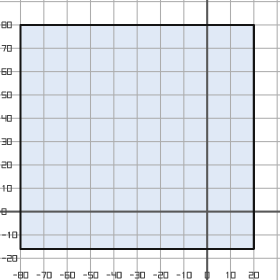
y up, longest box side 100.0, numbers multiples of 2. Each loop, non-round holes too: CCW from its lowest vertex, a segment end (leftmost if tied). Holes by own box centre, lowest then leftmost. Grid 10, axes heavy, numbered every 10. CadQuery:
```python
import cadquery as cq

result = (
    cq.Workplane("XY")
    .moveTo(-80.0, -16.0)
    .lineTo(20.0, -16.0)
    .lineTo(20.0, 80.0)
    .lineTo(-80.0, 80.0)
    .close()
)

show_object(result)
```